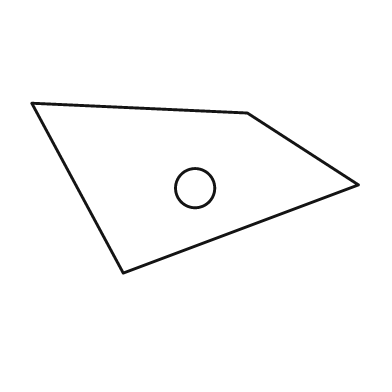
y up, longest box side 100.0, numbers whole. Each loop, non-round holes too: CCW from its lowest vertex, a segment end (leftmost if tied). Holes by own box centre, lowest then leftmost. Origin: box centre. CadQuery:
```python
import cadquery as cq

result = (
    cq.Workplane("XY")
    .moveTo(-22.0, -26.0)
    .lineTo(50.0, 1.0)
    .lineTo(16.0, 23.0)
    .lineTo(-50.0, 26.0)
    .close()
    .moveTo(0.0, 0.0)
    .circle(6.0)
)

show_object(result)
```